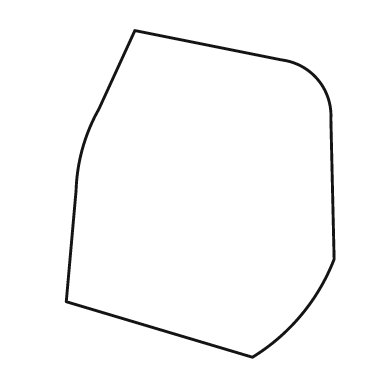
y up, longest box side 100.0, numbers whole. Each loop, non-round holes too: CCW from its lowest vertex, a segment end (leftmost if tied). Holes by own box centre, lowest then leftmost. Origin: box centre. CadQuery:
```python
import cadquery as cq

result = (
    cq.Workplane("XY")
    .moveTo(16.0, -50.0)
    .threePointArc((31.0, -37.0), (41.0, -20.0))
    .lineTo(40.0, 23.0)
    .threePointArc((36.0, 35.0), (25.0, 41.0))
    .lineTo(-20.0, 50.0)
    .lineTo(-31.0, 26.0)
    .threePointArc((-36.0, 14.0), (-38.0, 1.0))
    .lineTo(-41.0, -33.0)
    .close()
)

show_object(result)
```